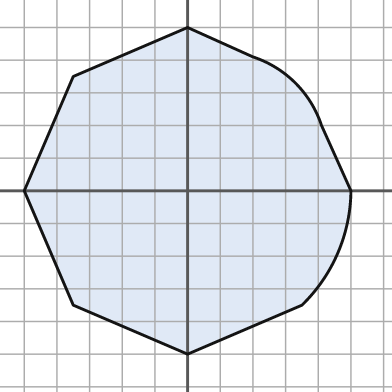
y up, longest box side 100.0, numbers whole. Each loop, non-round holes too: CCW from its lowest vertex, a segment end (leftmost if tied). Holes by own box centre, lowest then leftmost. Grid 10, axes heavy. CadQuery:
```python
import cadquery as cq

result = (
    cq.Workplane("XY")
    .moveTo(0.0, -50.0)
    .lineTo(35.0, -35.0)
    .threePointArc((46.0, -19.0), (50.0, 0.0))
    .lineTo(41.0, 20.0)
    .threePointArc((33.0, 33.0), (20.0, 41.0))
    .lineTo(0.0, 50.0)
    .lineTo(-35.0, 35.0)
    .lineTo(-50.0, 0.0)
    .lineTo(-35.0, -35.0)
    .close()
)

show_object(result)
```